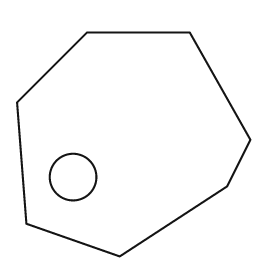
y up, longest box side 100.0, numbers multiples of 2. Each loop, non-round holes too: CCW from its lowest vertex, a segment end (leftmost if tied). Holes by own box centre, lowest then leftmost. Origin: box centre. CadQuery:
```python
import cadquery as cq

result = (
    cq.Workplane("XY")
    .moveTo(-6.0, -48.0)
    .lineTo(40.0, -18.0)
    .lineTo(50.0, 2.0)
    .lineTo(24.0, 48.0)
    .lineTo(-20.0, 48.0)
    .lineTo(-50.0, 18.0)
    .lineTo(-46.0, -34.0)
    .close()
    .moveTo(-26.0, -14.0)
    .circle(10.0)
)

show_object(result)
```